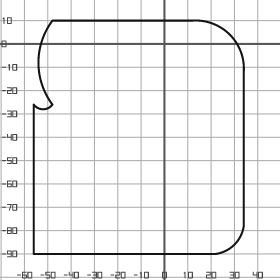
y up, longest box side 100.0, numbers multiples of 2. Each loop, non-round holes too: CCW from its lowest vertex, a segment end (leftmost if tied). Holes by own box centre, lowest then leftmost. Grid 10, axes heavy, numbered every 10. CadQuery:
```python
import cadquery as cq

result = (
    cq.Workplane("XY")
    .moveTo(-56.0, -90.0)
    .lineTo(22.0, -90.0)
    .threePointArc((30.0, -86.0), (34.0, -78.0))
    .lineTo(34.0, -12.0)
    .threePointArc((28.0, 4.0), (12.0, 10.0))
    .lineTo(-48.0, 10.0)
    .threePointArc((-54.0, -8.0), (-48.0, -26.0))
    .threePointArc((-52.0, -28.0), (-56.0, -26.0))
    .close()
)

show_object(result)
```